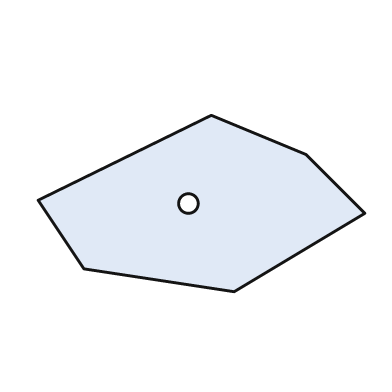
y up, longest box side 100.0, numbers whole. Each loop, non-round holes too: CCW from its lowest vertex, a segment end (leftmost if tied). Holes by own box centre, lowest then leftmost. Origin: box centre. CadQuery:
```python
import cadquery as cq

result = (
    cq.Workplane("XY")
    .moveTo(10.0, -27.0)
    .lineTo(50.0, -3.0)
    .lineTo(32.0, 15.0)
    .lineTo(3.0, 27.0)
    .lineTo(-50.0, 1.0)
    .lineTo(-36.0, -20.0)
    .close()
    .moveTo(-4.0, 0.0)
    .circle(3.0)
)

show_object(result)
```